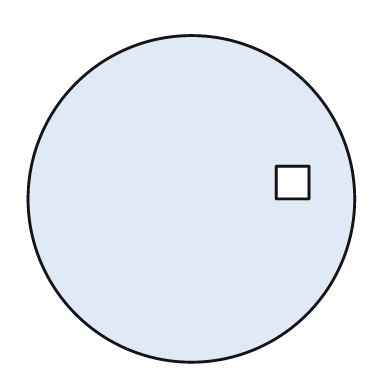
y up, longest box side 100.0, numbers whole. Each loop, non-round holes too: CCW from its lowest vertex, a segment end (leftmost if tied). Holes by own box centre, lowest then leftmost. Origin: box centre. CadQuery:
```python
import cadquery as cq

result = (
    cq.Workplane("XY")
    .moveTo(0.0, 0.0)
    .circle(50.0)
    .moveTo(26.0, 0.0)
    .lineTo(36.0, 0.0)
    .lineTo(36.0, 10.0)
    .lineTo(26.0, 10.0)
    .close()
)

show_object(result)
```